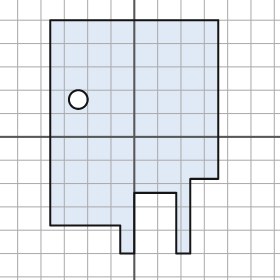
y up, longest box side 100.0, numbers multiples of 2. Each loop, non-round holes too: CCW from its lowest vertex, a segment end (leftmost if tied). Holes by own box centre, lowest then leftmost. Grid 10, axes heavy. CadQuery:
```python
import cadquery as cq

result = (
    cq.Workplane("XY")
    .moveTo(-6.0, -50.0)
    .lineTo(0.0, -50.0)
    .lineTo(0.0, -24.0)
    .lineTo(18.0, -24.0)
    .lineTo(18.0, -50.0)
    .lineTo(24.0, -50.0)
    .lineTo(24.0, -18.0)
    .lineTo(36.0, -18.0)
    .lineTo(36.0, 50.0)
    .lineTo(-36.0, 50.0)
    .lineTo(-36.0, -38.0)
    .lineTo(-6.0, -38.0)
    .close()
    .moveTo(-24.0, 16.0)
    .circle(4.0)
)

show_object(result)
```